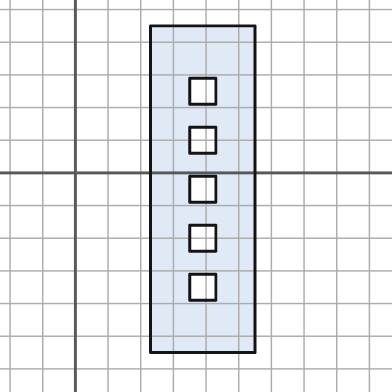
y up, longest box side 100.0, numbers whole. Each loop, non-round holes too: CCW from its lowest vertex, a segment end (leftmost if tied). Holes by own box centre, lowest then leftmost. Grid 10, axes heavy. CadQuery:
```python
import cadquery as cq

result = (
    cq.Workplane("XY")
    .moveTo(23.0, -55.0)
    .lineTo(55.0, -55.0)
    .lineTo(55.0, 45.0)
    .lineTo(23.0, 45.0)
    .close()
    .moveTo(35.0, -39.0)
    .lineTo(43.0, -39.0)
    .lineTo(43.0, -31.0)
    .lineTo(35.0, -31.0)
    .close()
    .moveTo(35.0, -24.0)
    .lineTo(43.0, -24.0)
    .lineTo(43.0, -16.0)
    .lineTo(35.0, -16.0)
    .close()
    .moveTo(35.0, -9.0)
    .lineTo(43.0, -9.0)
    .lineTo(43.0, -1.0)
    .lineTo(35.0, -1.0)
    .close()
    .moveTo(35.0, 6.0)
    .lineTo(43.0, 6.0)
    .lineTo(43.0, 14.0)
    .lineTo(35.0, 14.0)
    .close()
    .moveTo(35.0, 21.0)
    .lineTo(43.0, 21.0)
    .lineTo(43.0, 29.0)
    .lineTo(35.0, 29.0)
    .close()
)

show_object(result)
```